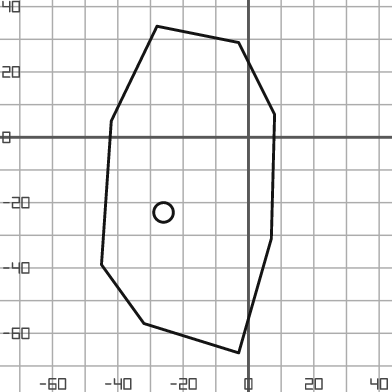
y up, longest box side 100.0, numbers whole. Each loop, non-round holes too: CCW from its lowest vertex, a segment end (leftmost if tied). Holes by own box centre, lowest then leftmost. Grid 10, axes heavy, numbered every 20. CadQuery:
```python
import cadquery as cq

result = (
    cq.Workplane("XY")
    .moveTo(-3.0, -66.0)
    .lineTo(7.0, -31.0)
    .lineTo(8.0, 7.0)
    .lineTo(-3.0, 29.0)
    .lineTo(-28.0, 34.0)
    .lineTo(-42.0, 5.0)
    .lineTo(-45.0, -39.0)
    .lineTo(-32.0, -57.0)
    .close()
    .moveTo(-26.0, -23.0)
    .circle(3.0)
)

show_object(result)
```